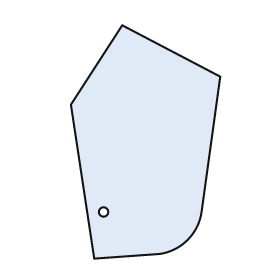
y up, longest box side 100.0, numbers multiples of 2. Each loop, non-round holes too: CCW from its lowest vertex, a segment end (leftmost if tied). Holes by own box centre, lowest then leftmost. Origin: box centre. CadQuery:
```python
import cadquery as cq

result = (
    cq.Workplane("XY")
    .moveTo(-22.0, -50.0)
    .lineTo(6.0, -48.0)
    .threePointArc((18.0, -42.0), (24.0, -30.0))
    .lineTo(32.0, 28.0)
    .lineTo(-10.0, 50.0)
    .lineTo(-32.0, 16.0)
    .close()
    .moveTo(-18.0, -30.0)
    .circle(2.0)
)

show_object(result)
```